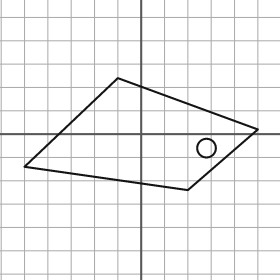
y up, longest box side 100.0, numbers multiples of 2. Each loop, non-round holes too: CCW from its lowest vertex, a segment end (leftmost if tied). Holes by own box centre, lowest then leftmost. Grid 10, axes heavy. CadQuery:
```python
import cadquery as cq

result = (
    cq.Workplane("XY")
    .moveTo(20.0, -24.0)
    .lineTo(50.0, 2.0)
    .lineTo(-10.0, 24.0)
    .lineTo(-50.0, -14.0)
    .close()
    .moveTo(28.0, -6.0)
    .circle(4.0)
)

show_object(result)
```